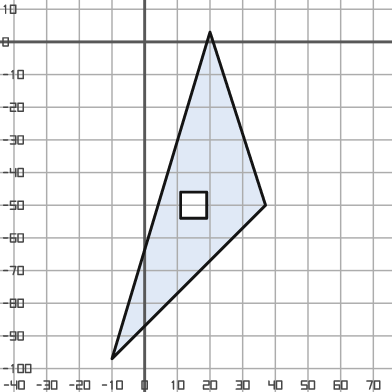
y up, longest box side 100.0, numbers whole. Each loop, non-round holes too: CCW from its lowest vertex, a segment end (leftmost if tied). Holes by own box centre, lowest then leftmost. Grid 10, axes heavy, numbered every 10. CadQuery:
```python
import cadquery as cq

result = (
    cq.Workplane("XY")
    .moveTo(-10.0, -97.0)
    .lineTo(37.0, -50.0)
    .lineTo(20.0, 3.0)
    .close()
    .moveTo(11.0, -54.0)
    .lineTo(19.0, -54.0)
    .lineTo(19.0, -46.0)
    .lineTo(11.0, -46.0)
    .close()
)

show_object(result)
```